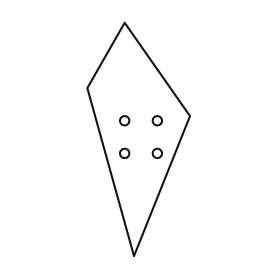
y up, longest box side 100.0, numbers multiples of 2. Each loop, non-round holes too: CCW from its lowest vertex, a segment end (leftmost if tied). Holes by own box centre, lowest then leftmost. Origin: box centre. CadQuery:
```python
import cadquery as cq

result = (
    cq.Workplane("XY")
    .moveTo(-2.0, -50.0)
    .lineTo(22.0, 10.0)
    .lineTo(-6.0, 50.0)
    .lineTo(-22.0, 22.0)
    .close()
    .moveTo(-6.0, -6.0)
    .circle(2.0)
    .moveTo(8.0, -6.0)
    .circle(2.0)
    .moveTo(-6.0, 8.0)
    .circle(2.0)
    .moveTo(8.0, 8.0)
    .circle(2.0)
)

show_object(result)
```